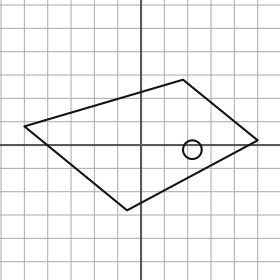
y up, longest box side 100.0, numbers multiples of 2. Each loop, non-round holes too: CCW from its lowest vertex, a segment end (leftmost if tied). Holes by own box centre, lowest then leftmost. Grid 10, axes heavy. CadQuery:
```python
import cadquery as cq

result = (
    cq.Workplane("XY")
    .moveTo(-6.0, -28.0)
    .lineTo(50.0, 2.0)
    .lineTo(18.0, 28.0)
    .lineTo(-50.0, 8.0)
    .close()
    .moveTo(22.0, -2.0)
    .circle(4.0)
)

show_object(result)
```